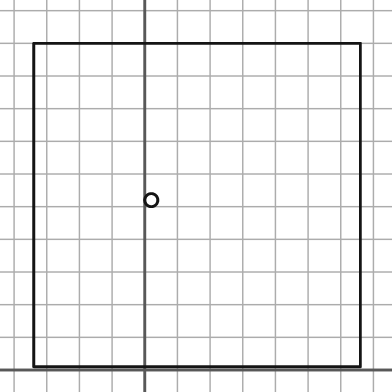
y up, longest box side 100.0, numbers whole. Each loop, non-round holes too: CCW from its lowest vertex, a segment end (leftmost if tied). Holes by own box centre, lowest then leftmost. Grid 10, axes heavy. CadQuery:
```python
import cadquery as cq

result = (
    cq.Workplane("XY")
    .moveTo(-34.0, 1.0)
    .lineTo(66.0, 1.0)
    .lineTo(66.0, 100.0)
    .lineTo(-34.0, 100.0)
    .close()
    .moveTo(2.0, 52.0)
    .circle(2.0)
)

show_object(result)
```